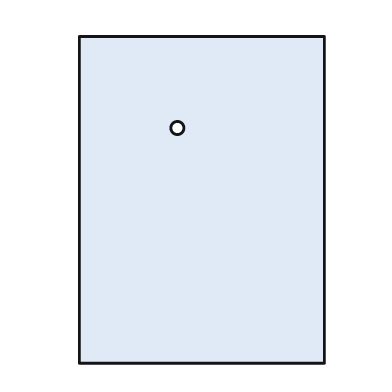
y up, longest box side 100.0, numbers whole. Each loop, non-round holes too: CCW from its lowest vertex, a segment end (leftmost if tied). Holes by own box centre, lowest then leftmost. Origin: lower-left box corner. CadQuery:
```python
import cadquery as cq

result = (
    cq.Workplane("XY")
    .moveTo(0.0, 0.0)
    .lineTo(75.0, 0.0)
    .lineTo(75.0, 100.0)
    .lineTo(0.0, 100.0)
    .close()
    .moveTo(30.0, 72.0)
    .circle(2.0)
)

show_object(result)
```